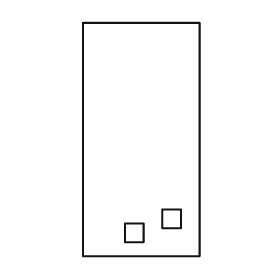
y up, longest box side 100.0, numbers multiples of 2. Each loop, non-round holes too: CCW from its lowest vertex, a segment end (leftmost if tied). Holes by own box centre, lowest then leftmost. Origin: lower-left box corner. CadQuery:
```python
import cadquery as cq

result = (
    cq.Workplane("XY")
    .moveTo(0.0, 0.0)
    .lineTo(50.0, 0.0)
    .lineTo(50.0, 100.0)
    .lineTo(0.0, 100.0)
    .close()
    .moveTo(18.0, 6.0)
    .lineTo(26.0, 6.0)
    .lineTo(26.0, 14.0)
    .lineTo(18.0, 14.0)
    .close()
    .moveTo(34.0, 12.0)
    .lineTo(42.0, 12.0)
    .lineTo(42.0, 20.0)
    .lineTo(34.0, 20.0)
    .close()
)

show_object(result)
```